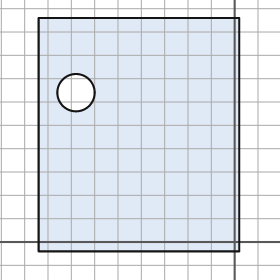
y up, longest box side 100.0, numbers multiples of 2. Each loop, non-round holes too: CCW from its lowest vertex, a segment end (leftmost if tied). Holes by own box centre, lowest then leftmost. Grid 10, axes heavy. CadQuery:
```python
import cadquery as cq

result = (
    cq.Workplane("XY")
    .moveTo(-84.0, -4.0)
    .lineTo(2.0, -4.0)
    .lineTo(2.0, 96.0)
    .lineTo(-84.0, 96.0)
    .close()
    .moveTo(-68.0, 64.0)
    .circle(8.0)
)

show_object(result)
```